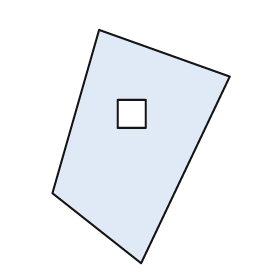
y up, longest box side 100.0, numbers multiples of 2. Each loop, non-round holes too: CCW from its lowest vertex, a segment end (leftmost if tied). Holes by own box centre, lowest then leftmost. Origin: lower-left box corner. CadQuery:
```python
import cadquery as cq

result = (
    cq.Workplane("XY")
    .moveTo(38.0, 0.0)
    .lineTo(76.0, 80.0)
    .lineTo(20.0, 100.0)
    .lineTo(0.0, 30.0)
    .close()
    .moveTo(28.0, 58.0)
    .lineTo(40.0, 58.0)
    .lineTo(40.0, 70.0)
    .lineTo(28.0, 70.0)
    .close()
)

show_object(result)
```